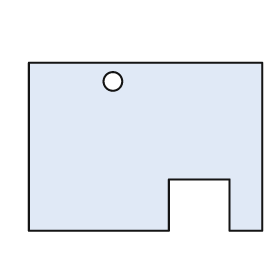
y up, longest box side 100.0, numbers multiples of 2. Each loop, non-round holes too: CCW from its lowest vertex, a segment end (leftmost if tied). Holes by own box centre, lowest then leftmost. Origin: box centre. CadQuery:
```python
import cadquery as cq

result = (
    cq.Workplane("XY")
    .moveTo(-50.0, -36.0)
    .lineTo(10.0, -36.0)
    .lineTo(10.0, -14.0)
    .lineTo(36.0, -14.0)
    .lineTo(36.0, -36.0)
    .lineTo(50.0, -36.0)
    .lineTo(50.0, 36.0)
    .lineTo(-50.0, 36.0)
    .close()
    .moveTo(-14.0, 28.0)
    .circle(4.0)
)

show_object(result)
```